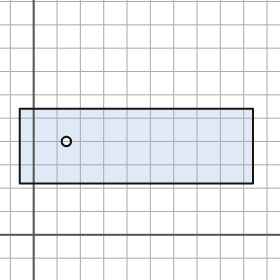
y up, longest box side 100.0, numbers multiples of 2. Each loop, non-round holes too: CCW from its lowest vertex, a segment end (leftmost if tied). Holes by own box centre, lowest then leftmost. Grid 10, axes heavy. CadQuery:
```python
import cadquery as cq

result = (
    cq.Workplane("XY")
    .moveTo(-6.0, 22.0)
    .lineTo(94.0, 22.0)
    .lineTo(94.0, 54.0)
    .lineTo(-6.0, 54.0)
    .close()
    .moveTo(14.0, 40.0)
    .circle(2.0)
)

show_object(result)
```